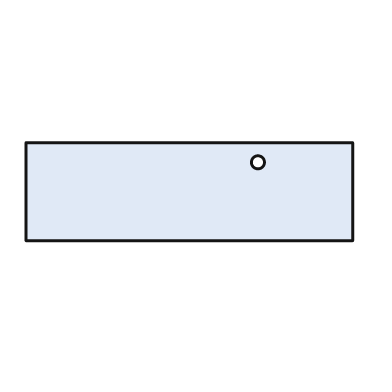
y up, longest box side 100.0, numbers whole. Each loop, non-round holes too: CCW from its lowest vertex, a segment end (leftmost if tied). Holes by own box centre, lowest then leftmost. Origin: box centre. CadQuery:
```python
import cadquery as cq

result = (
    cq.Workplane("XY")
    .moveTo(-50.0, -15.0)
    .lineTo(50.0, -15.0)
    .lineTo(50.0, 15.0)
    .lineTo(-50.0, 15.0)
    .close()
    .moveTo(21.0, 9.0)
    .circle(2.0)
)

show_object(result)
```